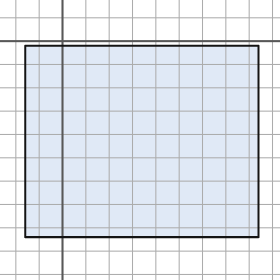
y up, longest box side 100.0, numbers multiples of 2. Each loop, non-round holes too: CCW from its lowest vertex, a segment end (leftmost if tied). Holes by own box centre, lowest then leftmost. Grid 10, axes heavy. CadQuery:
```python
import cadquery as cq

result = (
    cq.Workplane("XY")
    .moveTo(-16.0, -84.0)
    .lineTo(84.0, -84.0)
    .lineTo(84.0, -2.0)
    .lineTo(-16.0, -2.0)
    .close()
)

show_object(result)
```